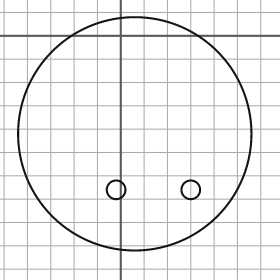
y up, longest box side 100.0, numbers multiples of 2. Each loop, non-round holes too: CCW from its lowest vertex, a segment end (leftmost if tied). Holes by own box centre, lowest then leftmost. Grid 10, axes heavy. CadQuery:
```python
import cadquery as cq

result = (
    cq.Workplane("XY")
    .moveTo(6.0, -42.0)
    .circle(50.0)
    .moveTo(-2.0, -66.0)
    .circle(4.0)
    .moveTo(30.0, -66.0)
    .circle(4.0)
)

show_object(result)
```